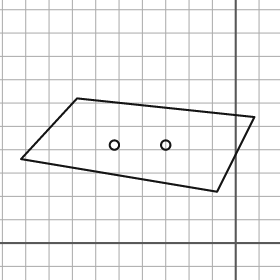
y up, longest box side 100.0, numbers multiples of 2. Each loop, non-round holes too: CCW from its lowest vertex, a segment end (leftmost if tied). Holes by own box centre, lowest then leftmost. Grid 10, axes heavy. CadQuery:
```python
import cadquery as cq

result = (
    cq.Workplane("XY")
    .moveTo(-8.0, 22.0)
    .lineTo(8.0, 54.0)
    .lineTo(-68.0, 62.0)
    .lineTo(-92.0, 36.0)
    .close()
    .moveTo(-52.0, 42.0)
    .circle(2.0)
    .moveTo(-30.0, 42.0)
    .circle(2.0)
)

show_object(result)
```